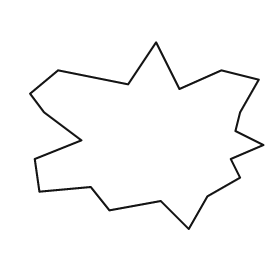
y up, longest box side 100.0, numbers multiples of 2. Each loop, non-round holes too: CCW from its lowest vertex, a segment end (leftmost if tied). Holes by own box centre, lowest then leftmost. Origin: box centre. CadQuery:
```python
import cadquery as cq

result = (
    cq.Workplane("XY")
    .moveTo(18.0, -40.0)
    .lineTo(26.0, -26.0)
    .lineTo(40.0, -18.0)
    .lineTo(36.0, -10.0)
    .lineTo(50.0, -4.0)
    .lineTo(38.0, 2.0)
    .lineTo(40.0, 10.0)
    .lineTo(48.0, 24.0)
    .lineTo(32.0, 28.0)
    .lineTo(14.0, 20.0)
    .lineTo(4.0, 40.0)
    .lineTo(-8.0, 22.0)
    .lineTo(-38.0, 28.0)
    .lineTo(-50.0, 18.0)
    .lineTo(-44.0, 10.0)
    .lineTo(-28.0, -2.0)
    .lineTo(-48.0, -10.0)
    .lineTo(-46.0, -24.0)
    .lineTo(-24.0, -22.0)
    .lineTo(-16.0, -32.0)
    .lineTo(6.0, -28.0)
    .close()
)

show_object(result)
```